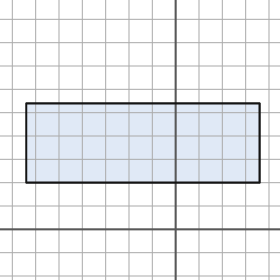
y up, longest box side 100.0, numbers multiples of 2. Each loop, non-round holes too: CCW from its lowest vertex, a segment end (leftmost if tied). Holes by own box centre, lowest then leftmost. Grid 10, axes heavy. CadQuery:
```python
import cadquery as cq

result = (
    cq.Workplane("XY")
    .moveTo(-64.0, 20.0)
    .lineTo(36.0, 20.0)
    .lineTo(36.0, 54.0)
    .lineTo(-64.0, 54.0)
    .close()
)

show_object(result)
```